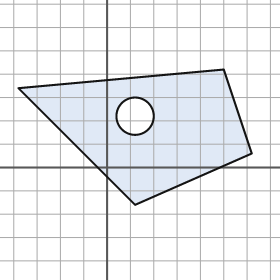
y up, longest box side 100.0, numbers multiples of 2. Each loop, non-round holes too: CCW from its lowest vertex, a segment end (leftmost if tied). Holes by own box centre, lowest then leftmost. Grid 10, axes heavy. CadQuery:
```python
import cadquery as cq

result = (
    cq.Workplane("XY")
    .moveTo(12.0, -16.0)
    .lineTo(62.0, 6.0)
    .lineTo(50.0, 42.0)
    .lineTo(-38.0, 34.0)
    .close()
    .moveTo(12.0, 22.0)
    .circle(8.0)
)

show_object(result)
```